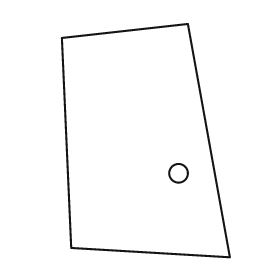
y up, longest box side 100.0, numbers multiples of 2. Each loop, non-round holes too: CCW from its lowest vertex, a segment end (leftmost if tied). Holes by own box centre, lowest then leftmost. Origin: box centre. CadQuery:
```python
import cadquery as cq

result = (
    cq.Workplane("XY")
    .moveTo(36.0, -50.0)
    .lineTo(18.0, 50.0)
    .lineTo(-36.0, 44.0)
    .lineTo(-32.0, -46.0)
    .close()
    .moveTo(14.0, -14.0)
    .circle(4.0)
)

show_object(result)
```